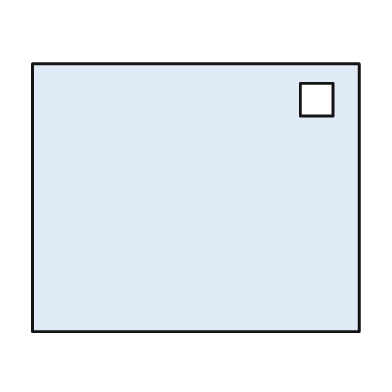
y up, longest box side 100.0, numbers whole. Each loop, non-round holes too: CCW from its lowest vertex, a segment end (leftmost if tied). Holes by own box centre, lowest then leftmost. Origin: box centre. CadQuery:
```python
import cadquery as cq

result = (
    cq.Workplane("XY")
    .moveTo(-50.0, -41.0)
    .lineTo(50.0, -41.0)
    .lineTo(50.0, 41.0)
    .lineTo(-50.0, 41.0)
    .close()
    .moveTo(32.0, 25.0)
    .lineTo(42.0, 25.0)
    .lineTo(42.0, 35.0)
    .lineTo(32.0, 35.0)
    .close()
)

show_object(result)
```